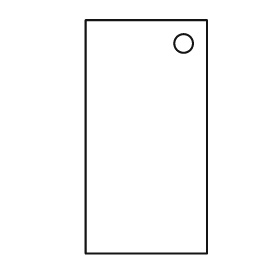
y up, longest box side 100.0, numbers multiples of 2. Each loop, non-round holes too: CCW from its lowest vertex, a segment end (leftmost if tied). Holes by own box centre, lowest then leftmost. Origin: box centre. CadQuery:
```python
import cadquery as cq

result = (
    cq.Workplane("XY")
    .moveTo(-26.0, -50.0)
    .lineTo(26.0, -50.0)
    .lineTo(26.0, 50.0)
    .lineTo(-26.0, 50.0)
    .close()
    .moveTo(16.0, 40.0)
    .circle(4.0)
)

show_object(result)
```